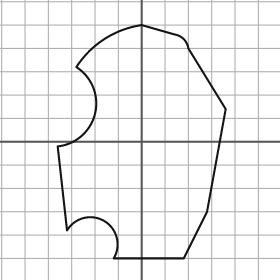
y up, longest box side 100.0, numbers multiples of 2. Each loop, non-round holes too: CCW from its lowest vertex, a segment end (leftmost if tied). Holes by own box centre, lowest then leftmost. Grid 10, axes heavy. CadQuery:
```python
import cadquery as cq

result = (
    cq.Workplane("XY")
    .moveTo(-12.0, -50.0)
    .lineTo(18.0, -50.0)
    .lineTo(28.0, -30.0)
    .lineTo(36.0, 14.0)
    .lineTo(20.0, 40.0)
    .threePointArc((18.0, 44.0), (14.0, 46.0))
    .lineTo(0.0, 50.0)
    .threePointArc((-16.0, 44.0), (-28.0, 32.0))
    .threePointArc((-20.0, 12.0), (-36.0, -2.0))
    .lineTo(-32.0, -38.0)
    .threePointArc((-16.0, -34.0), (-12.0, -50.0))
    .close()
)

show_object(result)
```